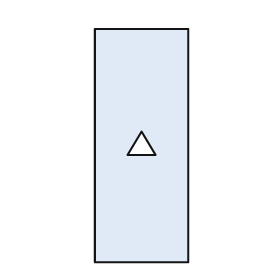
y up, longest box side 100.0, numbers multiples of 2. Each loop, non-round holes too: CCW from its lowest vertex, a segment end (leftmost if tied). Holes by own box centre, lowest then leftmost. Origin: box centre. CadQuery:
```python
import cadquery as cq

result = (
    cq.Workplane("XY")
    .moveTo(-20.0, -50.0)
    .lineTo(20.0, -50.0)
    .lineTo(20.0, 50.0)
    .lineTo(-20.0, 50.0)
    .close()
    .moveTo(-6.0, -4.0)
    .lineTo(6.0, -4.0)
    .lineTo(0.0, 6.0)
    .close()
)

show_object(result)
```